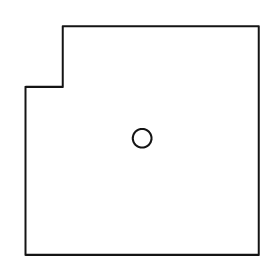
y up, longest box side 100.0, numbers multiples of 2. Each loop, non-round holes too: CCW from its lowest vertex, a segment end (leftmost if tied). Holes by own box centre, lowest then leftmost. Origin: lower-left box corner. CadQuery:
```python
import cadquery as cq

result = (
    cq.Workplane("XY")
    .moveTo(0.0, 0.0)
    .lineTo(100.0, 0.0)
    .lineTo(100.0, 98.0)
    .lineTo(16.0, 98.0)
    .lineTo(16.0, 72.0)
    .lineTo(0.0, 72.0)
    .close()
    .moveTo(50.0, 50.0)
    .circle(4.0)
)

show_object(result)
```